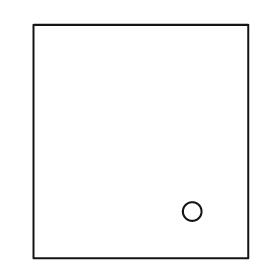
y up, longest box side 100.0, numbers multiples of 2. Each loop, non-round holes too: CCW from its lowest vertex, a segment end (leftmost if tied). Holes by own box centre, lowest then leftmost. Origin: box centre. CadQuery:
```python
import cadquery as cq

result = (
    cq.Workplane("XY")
    .moveTo(-46.0, -50.0)
    .lineTo(46.0, -50.0)
    .lineTo(46.0, 50.0)
    .lineTo(-46.0, 50.0)
    .close()
    .moveTo(22.0, -30.0)
    .circle(4.0)
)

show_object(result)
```